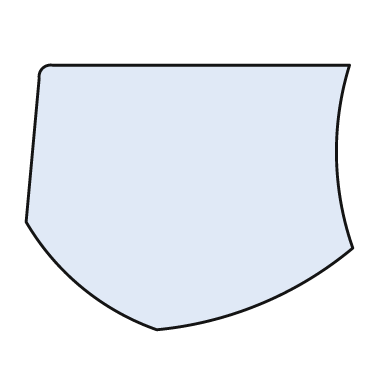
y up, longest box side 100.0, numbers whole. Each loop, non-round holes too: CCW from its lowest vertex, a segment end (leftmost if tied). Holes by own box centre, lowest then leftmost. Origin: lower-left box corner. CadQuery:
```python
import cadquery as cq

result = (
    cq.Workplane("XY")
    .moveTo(40.0, 0.0)
    .threePointArc((72.0, 8.0), (100.0, 25.0))
    .threePointArc((95.0, 53.0), (99.0, 81.0))
    .lineTo(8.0, 81.0)
    .threePointArc((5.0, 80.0), (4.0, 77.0))
    .lineTo(0.0, 33.0)
    .threePointArc((17.0, 13.0), (40.0, 0.0))
    .close()
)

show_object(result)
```